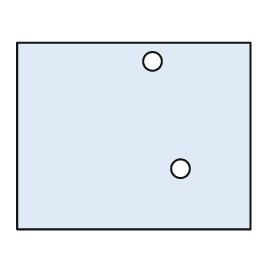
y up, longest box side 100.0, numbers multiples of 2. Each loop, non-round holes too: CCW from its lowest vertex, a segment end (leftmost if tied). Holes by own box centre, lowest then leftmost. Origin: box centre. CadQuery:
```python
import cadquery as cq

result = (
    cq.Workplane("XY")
    .moveTo(-50.0, -40.0)
    .lineTo(50.0, -40.0)
    .lineTo(50.0, 40.0)
    .lineTo(-50.0, 40.0)
    .close()
    .moveTo(20.0, -14.0)
    .circle(4.0)
    .moveTo(8.0, 32.0)
    .circle(4.0)
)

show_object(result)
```